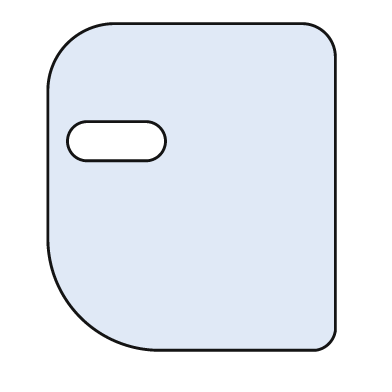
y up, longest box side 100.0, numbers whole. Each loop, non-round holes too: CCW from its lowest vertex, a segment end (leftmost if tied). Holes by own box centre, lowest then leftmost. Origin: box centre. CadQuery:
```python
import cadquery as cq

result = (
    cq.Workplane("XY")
    .moveTo(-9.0, -50.0)
    .lineTo(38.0, -50.0)
    .threePointArc((42.0, -48.0), (44.0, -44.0))
    .lineTo(44.0, 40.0)
    .threePointArc((41.0, 47.0), (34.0, 50.0))
    .lineTo(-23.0, 50.0)
    .threePointArc((-38.0, 44.0), (-44.0, 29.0))
    .lineTo(-44.0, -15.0)
    .threePointArc((-34.0, -40.0), (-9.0, -50.0))
    .close()
    .moveTo(-32.0, 8.0)
    .lineTo(-14.0, 8.0)
    .threePointArc((-8.0, 14.0), (-14.0, 20.0))
    .lineTo(-32.0, 20.0)
    .threePointArc((-38.0, 14.0), (-32.0, 8.0))
    .close()
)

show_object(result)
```